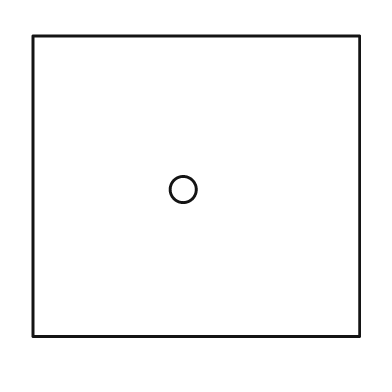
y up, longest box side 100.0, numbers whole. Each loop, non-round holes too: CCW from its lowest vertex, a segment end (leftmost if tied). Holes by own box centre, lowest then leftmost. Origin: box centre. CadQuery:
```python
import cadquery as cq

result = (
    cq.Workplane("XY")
    .moveTo(-50.0, -46.0)
    .lineTo(50.0, -46.0)
    .lineTo(50.0, 46.0)
    .lineTo(-50.0, 46.0)
    .close()
    .moveTo(-4.0, -1.0)
    .circle(4.0)
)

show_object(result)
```